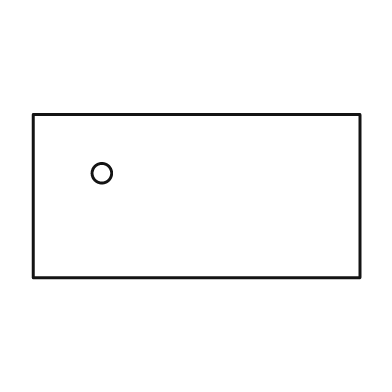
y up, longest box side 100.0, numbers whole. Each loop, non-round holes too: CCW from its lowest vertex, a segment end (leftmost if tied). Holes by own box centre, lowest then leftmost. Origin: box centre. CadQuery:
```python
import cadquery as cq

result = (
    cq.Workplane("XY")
    .moveTo(-50.0, -25.0)
    .lineTo(50.0, -25.0)
    .lineTo(50.0, 25.0)
    .lineTo(-50.0, 25.0)
    .close()
    .moveTo(-29.0, 7.0)
    .circle(3.0)
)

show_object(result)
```